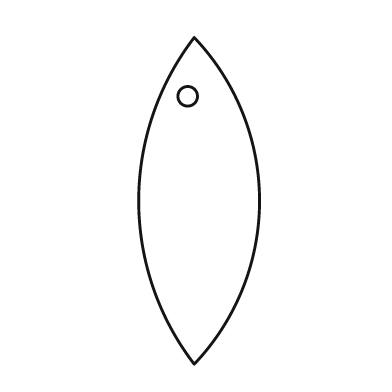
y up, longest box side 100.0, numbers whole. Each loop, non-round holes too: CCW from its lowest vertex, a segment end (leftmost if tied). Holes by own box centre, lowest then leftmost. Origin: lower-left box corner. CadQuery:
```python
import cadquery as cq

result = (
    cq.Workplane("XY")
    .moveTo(17.0, 0.0)
    .threePointArc((37.0, 50.0), (17.0, 100.0))
    .threePointArc((0.0, 50.0), (17.0, 0.0))
    .close()
    .moveTo(15.0, 82.0)
    .circle(3.0)
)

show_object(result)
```